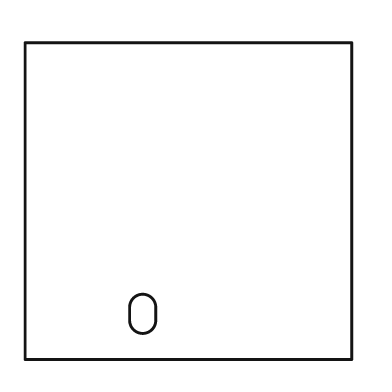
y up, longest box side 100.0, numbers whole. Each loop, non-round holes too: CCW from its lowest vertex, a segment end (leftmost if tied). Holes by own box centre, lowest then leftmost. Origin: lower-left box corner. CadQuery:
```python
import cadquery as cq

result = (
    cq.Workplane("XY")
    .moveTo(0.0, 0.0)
    .lineTo(100.0, 0.0)
    .lineTo(100.0, 97.0)
    .lineTo(0.0, 97.0)
    .close()
    .moveTo(32.0, 12.0)
    .threePointArc((36.0, 8.0), (40.0, 12.0))
    .lineTo(40.0, 16.0)
    .threePointArc((36.0, 20.0), (32.0, 16.0))
    .close()
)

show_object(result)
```